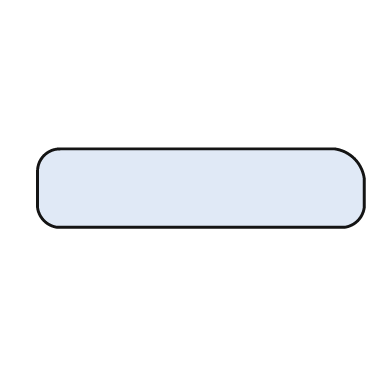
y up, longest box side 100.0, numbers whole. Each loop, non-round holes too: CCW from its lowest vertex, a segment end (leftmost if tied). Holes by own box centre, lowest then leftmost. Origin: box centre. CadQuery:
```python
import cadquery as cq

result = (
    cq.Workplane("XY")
    .moveTo(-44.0, -12.0)
    .lineTo(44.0, -12.0)
    .threePointArc((48.0, -10.0), (50.0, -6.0))
    .lineTo(50.0, 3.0)
    .threePointArc((47.0, 9.0), (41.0, 12.0))
    .lineTo(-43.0, 12.0)
    .threePointArc((-48.0, 10.0), (-50.0, 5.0))
    .lineTo(-50.0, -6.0)
    .threePointArc((-48.0, -10.0), (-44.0, -12.0))
    .close()
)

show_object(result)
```